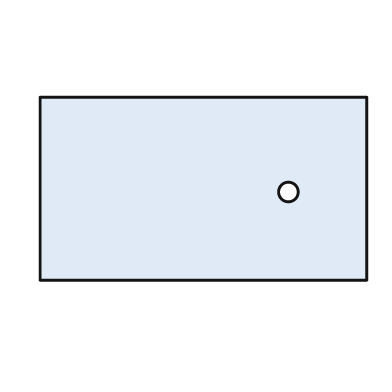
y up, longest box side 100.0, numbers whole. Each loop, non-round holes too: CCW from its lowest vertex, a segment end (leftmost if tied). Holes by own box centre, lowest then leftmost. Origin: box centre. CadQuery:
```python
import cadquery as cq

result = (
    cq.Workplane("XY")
    .moveTo(-50.0, -28.0)
    .lineTo(50.0, -28.0)
    .lineTo(50.0, 28.0)
    .lineTo(-50.0, 28.0)
    .close()
    .moveTo(26.0, -1.0)
    .circle(3.0)
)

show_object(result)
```